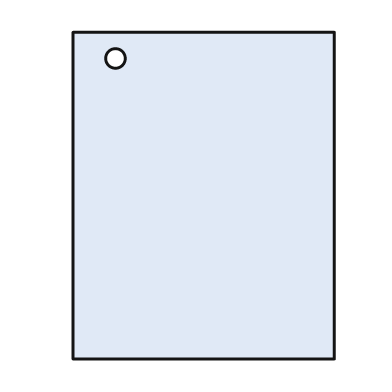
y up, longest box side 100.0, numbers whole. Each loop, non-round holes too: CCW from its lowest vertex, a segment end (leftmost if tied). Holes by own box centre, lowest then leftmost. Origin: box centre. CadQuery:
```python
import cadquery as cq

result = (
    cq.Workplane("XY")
    .moveTo(-40.0, -50.0)
    .lineTo(40.0, -50.0)
    .lineTo(40.0, 50.0)
    .lineTo(-40.0, 50.0)
    .close()
    .moveTo(-27.0, 42.0)
    .circle(3.0)
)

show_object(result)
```